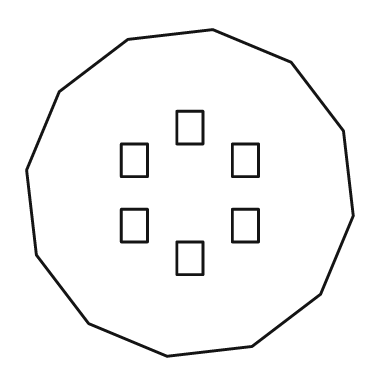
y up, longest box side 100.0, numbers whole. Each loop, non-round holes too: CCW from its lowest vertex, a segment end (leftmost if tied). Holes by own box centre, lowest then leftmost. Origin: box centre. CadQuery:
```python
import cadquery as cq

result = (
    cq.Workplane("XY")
    .moveTo(-7.0, -50.0)
    .lineTo(19.0, -47.0)
    .lineTo(40.0, -31.0)
    .lineTo(50.0, -7.0)
    .lineTo(47.0, 19.0)
    .lineTo(31.0, 40.0)
    .lineTo(7.0, 50.0)
    .lineTo(-19.0, 47.0)
    .lineTo(-40.0, 31.0)
    .lineTo(-50.0, 7.0)
    .lineTo(-47.0, -19.0)
    .lineTo(-31.0, -40.0)
    .close()
    .moveTo(-4.0, -25.0)
    .lineTo(4.0, -25.0)
    .lineTo(4.0, -15.0)
    .lineTo(-4.0, -15.0)
    .close()
    .moveTo(-21.0, -15.0)
    .lineTo(-13.0, -15.0)
    .lineTo(-13.0, -5.0)
    .lineTo(-21.0, -5.0)
    .close()
    .moveTo(13.0, -15.0)
    .lineTo(21.0, -15.0)
    .lineTo(21.0, -5.0)
    .lineTo(13.0, -5.0)
    .close()
    .moveTo(-21.0, 5.0)
    .lineTo(-13.0, 5.0)
    .lineTo(-13.0, 15.0)
    .lineTo(-21.0, 15.0)
    .close()
    .moveTo(13.0, 5.0)
    .lineTo(21.0, 5.0)
    .lineTo(21.0, 15.0)
    .lineTo(13.0, 15.0)
    .close()
    .moveTo(-4.0, 15.0)
    .lineTo(4.0, 15.0)
    .lineTo(4.0, 25.0)
    .lineTo(-4.0, 25.0)
    .close()
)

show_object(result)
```